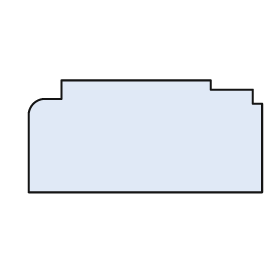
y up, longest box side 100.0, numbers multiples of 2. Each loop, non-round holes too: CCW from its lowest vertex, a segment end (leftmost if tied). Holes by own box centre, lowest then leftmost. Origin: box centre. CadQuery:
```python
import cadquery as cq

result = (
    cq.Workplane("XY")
    .moveTo(-50.0, -24.0)
    .lineTo(50.0, -24.0)
    .lineTo(50.0, 14.0)
    .lineTo(46.0, 14.0)
    .lineTo(46.0, 20.0)
    .lineTo(28.0, 20.0)
    .lineTo(28.0, 24.0)
    .lineTo(-36.0, 24.0)
    .lineTo(-36.0, 16.0)
    .lineTo(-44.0, 16.0)
    .threePointArc((-48.0, 14.0), (-50.0, 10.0))
    .close()
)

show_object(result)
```